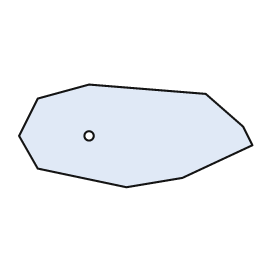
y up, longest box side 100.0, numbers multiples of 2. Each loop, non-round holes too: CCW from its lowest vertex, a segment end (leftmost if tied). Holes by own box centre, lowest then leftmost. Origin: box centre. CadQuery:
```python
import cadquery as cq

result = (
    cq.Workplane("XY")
    .moveTo(-4.0, -22.0)
    .lineTo(20.0, -18.0)
    .lineTo(50.0, -4.0)
    .lineTo(46.0, 4.0)
    .lineTo(30.0, 18.0)
    .lineTo(-20.0, 22.0)
    .lineTo(-42.0, 16.0)
    .lineTo(-50.0, 0.0)
    .lineTo(-42.0, -14.0)
    .close()
    .moveTo(-20.0, 0.0)
    .circle(2.0)
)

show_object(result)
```